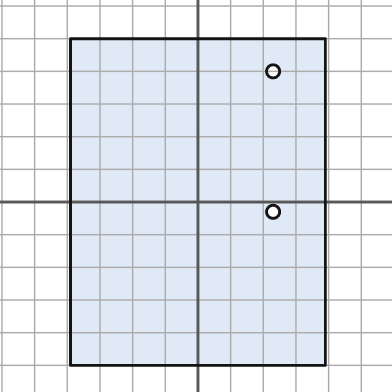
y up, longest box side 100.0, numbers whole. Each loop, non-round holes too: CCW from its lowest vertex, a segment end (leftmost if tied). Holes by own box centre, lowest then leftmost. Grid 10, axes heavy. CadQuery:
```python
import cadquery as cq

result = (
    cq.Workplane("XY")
    .moveTo(-39.0, -50.0)
    .lineTo(39.0, -50.0)
    .lineTo(39.0, 50.0)
    .lineTo(-39.0, 50.0)
    .close()
    .moveTo(23.0, -3.0)
    .circle(2.0)
    .moveTo(23.0, 40.0)
    .circle(2.0)
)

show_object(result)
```